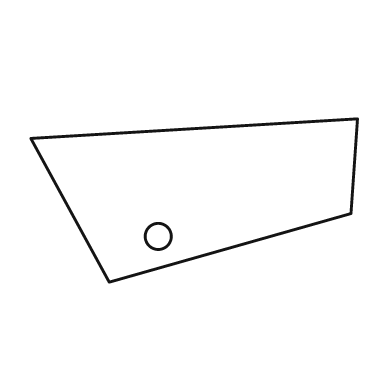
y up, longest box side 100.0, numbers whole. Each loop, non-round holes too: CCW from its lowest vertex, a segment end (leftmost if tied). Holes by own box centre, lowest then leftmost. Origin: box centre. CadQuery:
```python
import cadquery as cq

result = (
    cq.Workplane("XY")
    .moveTo(-26.0, -25.0)
    .lineTo(48.0, -4.0)
    .lineTo(50.0, 25.0)
    .lineTo(-50.0, 19.0)
    .close()
    .moveTo(-11.0, -11.0)
    .circle(4.0)
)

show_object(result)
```